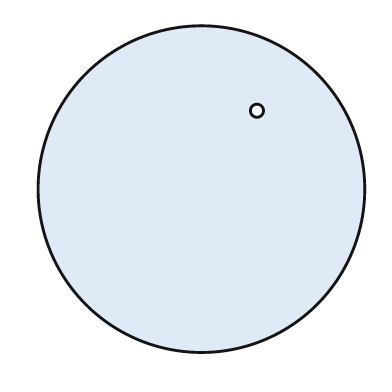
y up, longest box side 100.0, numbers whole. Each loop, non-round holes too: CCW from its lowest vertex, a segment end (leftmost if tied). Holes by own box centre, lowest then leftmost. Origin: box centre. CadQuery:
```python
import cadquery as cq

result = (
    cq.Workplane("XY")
    .moveTo(0.0, 0.0)
    .circle(50.0)
    .moveTo(17.0, 24.0)
    .circle(2.0)
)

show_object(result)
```